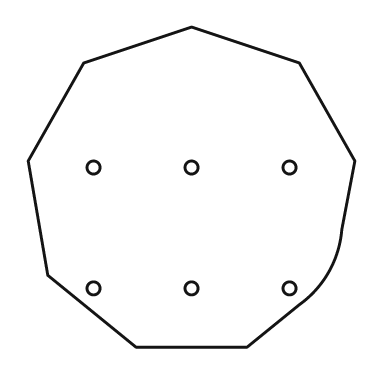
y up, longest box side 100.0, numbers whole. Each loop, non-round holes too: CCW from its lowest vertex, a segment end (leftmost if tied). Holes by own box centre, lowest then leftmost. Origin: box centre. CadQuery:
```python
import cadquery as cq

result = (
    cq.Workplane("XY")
    .moveTo(-17.0, -49.0)
    .lineTo(17.0, -49.0)
    .lineTo(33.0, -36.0)
    .threePointArc((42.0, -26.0), (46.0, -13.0))
    .lineTo(50.0, 8.0)
    .lineTo(33.0, 38.0)
    .lineTo(0.0, 49.0)
    .lineTo(-33.0, 38.0)
    .lineTo(-50.0, 8.0)
    .lineTo(-44.0, -27.0)
    .close()
    .moveTo(-30.0, -31.0)
    .circle(2.0)
    .moveTo(0.0, -31.0)
    .circle(2.0)
    .moveTo(30.0, -31.0)
    .circle(2.0)
    .moveTo(-30.0, 6.0)
    .circle(2.0)
    .moveTo(0.0, 6.0)
    .circle(2.0)
    .moveTo(30.0, 6.0)
    .circle(2.0)
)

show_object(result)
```